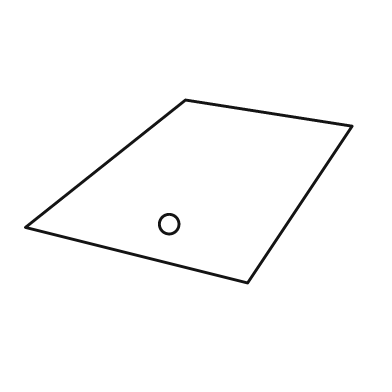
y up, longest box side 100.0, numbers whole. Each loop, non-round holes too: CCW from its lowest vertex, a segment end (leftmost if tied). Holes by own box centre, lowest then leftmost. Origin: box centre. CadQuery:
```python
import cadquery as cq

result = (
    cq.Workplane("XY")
    .moveTo(18.0, -28.0)
    .lineTo(50.0, 20.0)
    .lineTo(-1.0, 28.0)
    .lineTo(-50.0, -11.0)
    .close()
    .moveTo(-6.0, -10.0)
    .circle(3.0)
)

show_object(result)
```